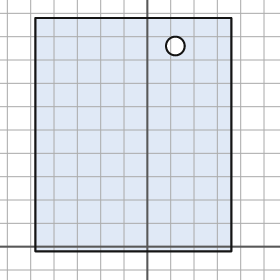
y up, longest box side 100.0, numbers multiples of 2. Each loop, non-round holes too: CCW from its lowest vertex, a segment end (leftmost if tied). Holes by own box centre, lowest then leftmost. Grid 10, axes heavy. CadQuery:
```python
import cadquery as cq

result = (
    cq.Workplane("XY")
    .moveTo(-48.0, -2.0)
    .lineTo(36.0, -2.0)
    .lineTo(36.0, 98.0)
    .lineTo(-48.0, 98.0)
    .close()
    .moveTo(12.0, 86.0)
    .circle(4.0)
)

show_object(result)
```